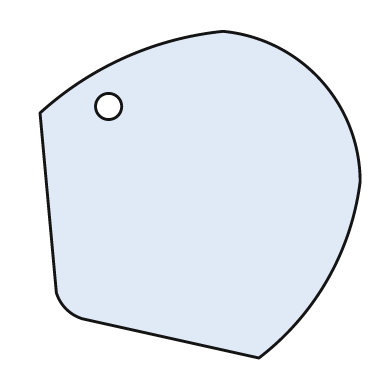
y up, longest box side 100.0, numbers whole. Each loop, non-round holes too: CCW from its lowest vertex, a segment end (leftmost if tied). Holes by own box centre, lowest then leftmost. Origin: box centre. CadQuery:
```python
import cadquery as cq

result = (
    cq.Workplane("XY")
    .moveTo(18.0, -50.0)
    .threePointArc((39.0, -26.0), (49.0, 4.0))
    .threePointArc((37.0, 35.0), (7.0, 50.0))
    .threePointArc((-23.0, 42.0), (-49.0, 25.0))
    .lineTo(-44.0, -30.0)
    .threePointArc((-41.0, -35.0), (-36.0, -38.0))
    .close()
    .moveTo(-28.0, 27.0)
    .circle(4.0)
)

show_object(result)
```